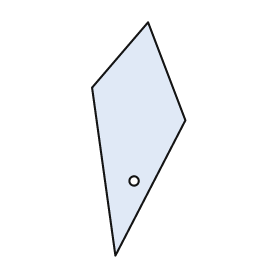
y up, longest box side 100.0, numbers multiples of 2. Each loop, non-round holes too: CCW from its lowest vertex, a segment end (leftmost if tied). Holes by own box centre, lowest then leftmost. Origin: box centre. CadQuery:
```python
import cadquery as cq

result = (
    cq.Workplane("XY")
    .moveTo(-10.0, -50.0)
    .lineTo(20.0, 8.0)
    .lineTo(4.0, 50.0)
    .lineTo(-20.0, 22.0)
    .close()
    .moveTo(-2.0, -18.0)
    .circle(2.0)
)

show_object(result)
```